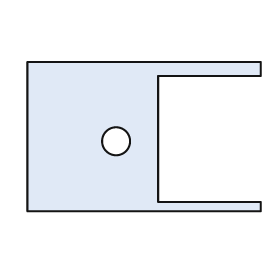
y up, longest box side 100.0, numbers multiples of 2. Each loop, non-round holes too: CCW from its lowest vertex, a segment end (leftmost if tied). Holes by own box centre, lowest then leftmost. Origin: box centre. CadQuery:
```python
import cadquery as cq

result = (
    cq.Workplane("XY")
    .moveTo(-50.0, -32.0)
    .lineTo(50.0, -32.0)
    .lineTo(50.0, -28.0)
    .lineTo(6.0, -28.0)
    .lineTo(6.0, 26.0)
    .lineTo(50.0, 26.0)
    .lineTo(50.0, 32.0)
    .lineTo(-50.0, 32.0)
    .close()
    .moveTo(-12.0, -2.0)
    .circle(6.0)
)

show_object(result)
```